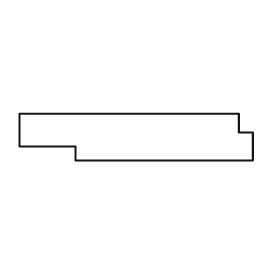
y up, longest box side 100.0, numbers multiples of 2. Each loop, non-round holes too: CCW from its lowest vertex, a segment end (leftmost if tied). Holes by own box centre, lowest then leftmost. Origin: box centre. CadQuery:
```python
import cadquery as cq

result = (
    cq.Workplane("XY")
    .moveTo(-26.0, -10.0)
    .lineTo(50.0, -10.0)
    .lineTo(50.0, 2.0)
    .lineTo(44.0, 2.0)
    .lineTo(44.0, 10.0)
    .lineTo(-50.0, 10.0)
    .lineTo(-50.0, -4.0)
    .lineTo(-26.0, -4.0)
    .close()
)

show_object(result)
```